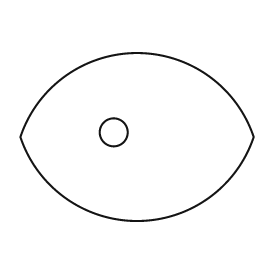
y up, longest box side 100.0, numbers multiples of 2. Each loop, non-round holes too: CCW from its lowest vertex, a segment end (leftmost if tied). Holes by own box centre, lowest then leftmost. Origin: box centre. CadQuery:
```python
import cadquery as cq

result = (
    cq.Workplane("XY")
    .moveTo(-50.0, 0.0)
    .threePointArc((0.0, -36.0), (50.0, 0.0))
    .threePointArc((0.0, 36.0), (-50.0, 0.0))
    .close()
    .moveTo(-10.0, 2.0)
    .circle(6.0)
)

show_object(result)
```